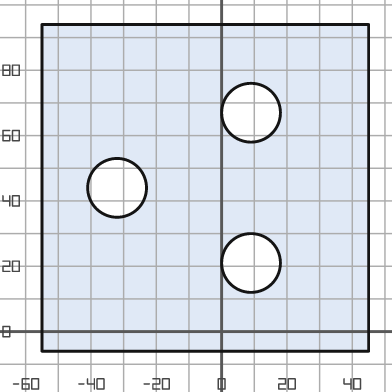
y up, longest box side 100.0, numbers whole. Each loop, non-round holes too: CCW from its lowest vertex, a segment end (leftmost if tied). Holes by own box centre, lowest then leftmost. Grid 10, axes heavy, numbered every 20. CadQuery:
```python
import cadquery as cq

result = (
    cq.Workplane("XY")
    .moveTo(-55.0, -6.0)
    .lineTo(45.0, -6.0)
    .lineTo(45.0, 94.0)
    .lineTo(-55.0, 94.0)
    .close()
    .moveTo(9.0, 21.0)
    .circle(9.0)
    .moveTo(-32.0, 44.0)
    .circle(9.0)
    .moveTo(9.0, 67.0)
    .circle(9.0)
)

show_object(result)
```